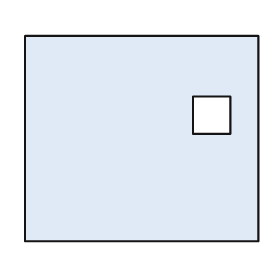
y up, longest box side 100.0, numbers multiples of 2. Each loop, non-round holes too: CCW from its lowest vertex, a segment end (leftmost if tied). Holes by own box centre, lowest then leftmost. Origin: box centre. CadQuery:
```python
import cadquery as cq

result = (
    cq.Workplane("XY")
    .moveTo(-50.0, -44.0)
    .lineTo(50.0, -44.0)
    .lineTo(50.0, 44.0)
    .lineTo(-50.0, 44.0)
    .close()
    .moveTo(22.0, 2.0)
    .lineTo(38.0, 2.0)
    .lineTo(38.0, 18.0)
    .lineTo(22.0, 18.0)
    .close()
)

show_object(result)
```